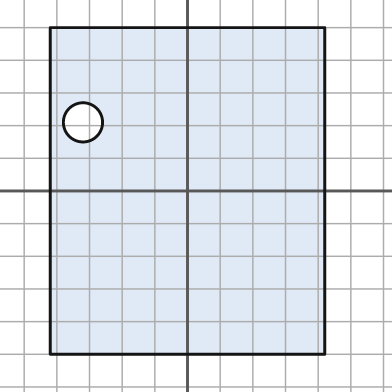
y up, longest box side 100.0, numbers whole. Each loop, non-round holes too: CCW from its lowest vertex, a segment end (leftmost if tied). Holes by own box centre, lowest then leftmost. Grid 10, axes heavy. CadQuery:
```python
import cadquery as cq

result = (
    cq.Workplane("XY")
    .moveTo(-42.0, -50.0)
    .lineTo(42.0, -50.0)
    .lineTo(42.0, 50.0)
    .lineTo(-42.0, 50.0)
    .close()
    .moveTo(-32.0, 21.0)
    .circle(6.0)
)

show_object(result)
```